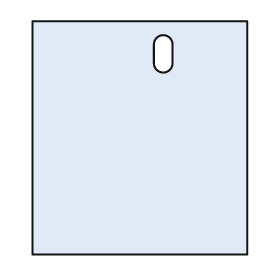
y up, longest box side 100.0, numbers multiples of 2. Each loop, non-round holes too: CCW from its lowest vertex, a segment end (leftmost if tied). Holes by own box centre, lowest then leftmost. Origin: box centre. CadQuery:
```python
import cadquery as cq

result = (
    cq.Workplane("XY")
    .moveTo(-46.0, -50.0)
    .lineTo(46.0, -50.0)
    .lineTo(46.0, 50.0)
    .lineTo(-46.0, 50.0)
    .close()
    .moveTo(6.0, 32.0)
    .threePointArc((10.0, 28.0), (14.0, 32.0))
    .lineTo(14.0, 40.0)
    .threePointArc((10.0, 44.0), (6.0, 40.0))
    .close()
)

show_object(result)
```